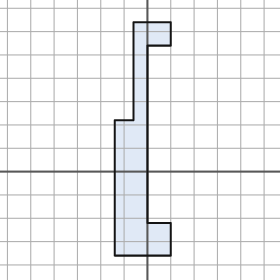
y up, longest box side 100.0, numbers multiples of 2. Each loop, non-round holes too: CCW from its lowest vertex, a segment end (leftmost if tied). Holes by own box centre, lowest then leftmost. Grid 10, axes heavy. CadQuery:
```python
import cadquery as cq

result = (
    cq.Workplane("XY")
    .moveTo(-14.0, -36.0)
    .lineTo(10.0, -36.0)
    .lineTo(10.0, -22.0)
    .lineTo(0.0, -22.0)
    .lineTo(0.0, 54.0)
    .lineTo(10.0, 54.0)
    .lineTo(10.0, 64.0)
    .lineTo(-6.0, 64.0)
    .lineTo(-6.0, 22.0)
    .lineTo(-14.0, 22.0)
    .close()
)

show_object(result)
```